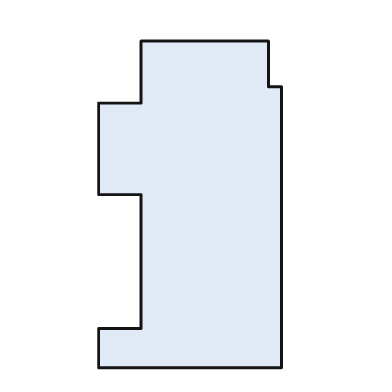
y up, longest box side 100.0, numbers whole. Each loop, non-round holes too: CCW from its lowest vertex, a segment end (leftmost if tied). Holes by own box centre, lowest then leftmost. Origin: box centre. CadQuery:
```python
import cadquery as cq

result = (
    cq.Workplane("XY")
    .moveTo(-28.0, -50.0)
    .lineTo(28.0, -50.0)
    .lineTo(28.0, 36.0)
    .lineTo(24.0, 36.0)
    .lineTo(24.0, 50.0)
    .lineTo(-15.0, 50.0)
    .lineTo(-15.0, 31.0)
    .lineTo(-28.0, 31.0)
    .lineTo(-28.0, 3.0)
    .lineTo(-15.0, 3.0)
    .lineTo(-15.0, -38.0)
    .lineTo(-28.0, -38.0)
    .close()
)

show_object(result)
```